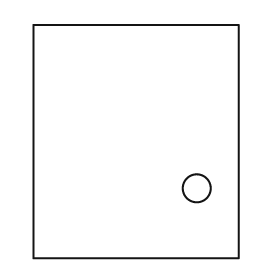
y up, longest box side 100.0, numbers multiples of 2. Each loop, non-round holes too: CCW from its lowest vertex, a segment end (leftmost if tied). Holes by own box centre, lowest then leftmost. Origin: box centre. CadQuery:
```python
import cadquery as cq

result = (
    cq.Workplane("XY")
    .moveTo(-44.0, -50.0)
    .lineTo(44.0, -50.0)
    .lineTo(44.0, 50.0)
    .lineTo(-44.0, 50.0)
    .close()
    .moveTo(26.0, -20.0)
    .circle(6.0)
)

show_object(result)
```